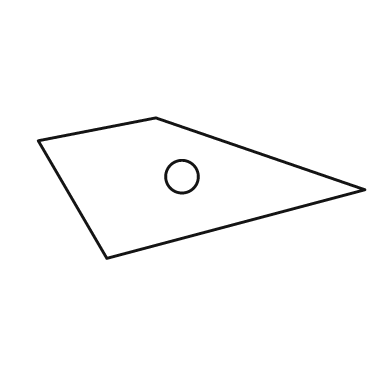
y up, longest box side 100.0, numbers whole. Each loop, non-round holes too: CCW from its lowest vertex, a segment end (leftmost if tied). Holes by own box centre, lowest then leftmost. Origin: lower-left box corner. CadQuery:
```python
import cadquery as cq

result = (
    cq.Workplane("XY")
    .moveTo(21.0, 0.0)
    .lineTo(100.0, 21.0)
    .lineTo(36.0, 43.0)
    .lineTo(0.0, 36.0)
    .close()
    .moveTo(44.0, 25.0)
    .circle(5.0)
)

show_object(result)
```